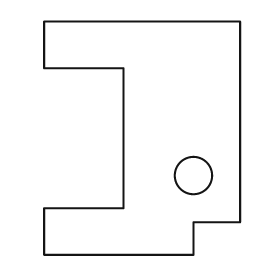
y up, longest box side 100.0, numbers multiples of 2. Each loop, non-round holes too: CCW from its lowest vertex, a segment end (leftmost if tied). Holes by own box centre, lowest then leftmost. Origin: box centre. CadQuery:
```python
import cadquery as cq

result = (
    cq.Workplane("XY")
    .moveTo(-42.0, -50.0)
    .lineTo(22.0, -50.0)
    .lineTo(22.0, -36.0)
    .lineTo(42.0, -36.0)
    .lineTo(42.0, 50.0)
    .lineTo(-42.0, 50.0)
    .lineTo(-42.0, 30.0)
    .lineTo(-8.0, 30.0)
    .lineTo(-8.0, -30.0)
    .lineTo(-42.0, -30.0)
    .close()
    .moveTo(22.0, -16.0)
    .circle(8.0)
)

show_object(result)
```